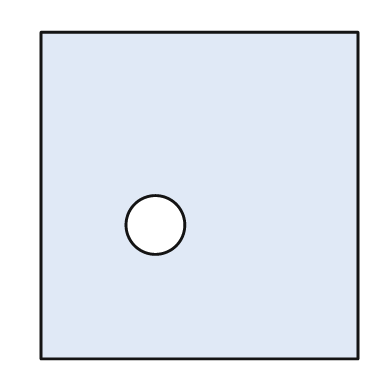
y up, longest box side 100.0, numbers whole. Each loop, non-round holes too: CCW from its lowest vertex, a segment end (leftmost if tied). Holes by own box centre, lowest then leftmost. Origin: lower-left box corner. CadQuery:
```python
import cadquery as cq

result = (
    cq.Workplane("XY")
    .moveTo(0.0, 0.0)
    .lineTo(97.0, 0.0)
    .lineTo(97.0, 100.0)
    .lineTo(0.0, 100.0)
    .close()
    .moveTo(35.0, 41.0)
    .circle(9.0)
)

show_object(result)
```